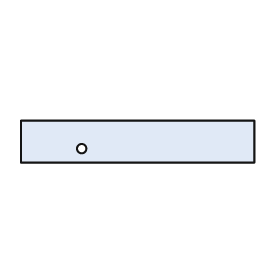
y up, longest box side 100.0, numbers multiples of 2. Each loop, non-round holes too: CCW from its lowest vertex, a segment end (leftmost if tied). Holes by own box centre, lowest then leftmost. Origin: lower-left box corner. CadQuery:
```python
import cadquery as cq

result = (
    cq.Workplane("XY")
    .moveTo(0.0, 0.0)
    .lineTo(100.0, 0.0)
    .lineTo(100.0, 18.0)
    .lineTo(0.0, 18.0)
    .close()
    .moveTo(26.0, 6.0)
    .circle(2.0)
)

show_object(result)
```